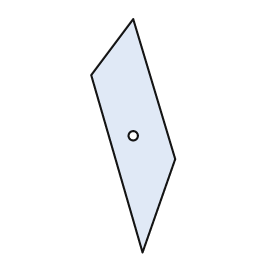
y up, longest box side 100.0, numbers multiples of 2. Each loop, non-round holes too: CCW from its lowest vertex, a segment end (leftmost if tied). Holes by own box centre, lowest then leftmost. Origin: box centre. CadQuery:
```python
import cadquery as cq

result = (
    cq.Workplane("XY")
    .moveTo(4.0, -50.0)
    .lineTo(18.0, -10.0)
    .lineTo(0.0, 50.0)
    .lineTo(-18.0, 26.0)
    .close()
    .moveTo(0.0, 0.0)
    .circle(2.0)
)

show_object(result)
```